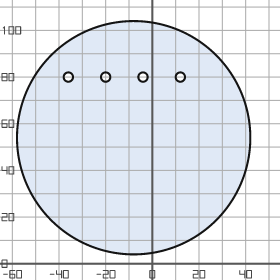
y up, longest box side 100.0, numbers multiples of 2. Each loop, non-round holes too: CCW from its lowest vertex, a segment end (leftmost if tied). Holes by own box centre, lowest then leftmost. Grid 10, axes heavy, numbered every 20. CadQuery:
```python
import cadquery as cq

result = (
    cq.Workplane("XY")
    .moveTo(-8.0, 54.0)
    .circle(50.0)
    .moveTo(-36.0, 80.0)
    .circle(2.0)
    .moveTo(-20.0, 80.0)
    .circle(2.0)
    .moveTo(-4.0, 80.0)
    .circle(2.0)
    .moveTo(12.0, 80.0)
    .circle(2.0)
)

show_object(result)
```